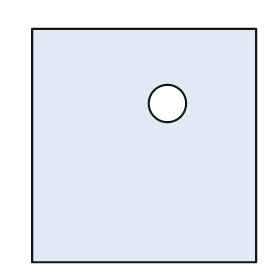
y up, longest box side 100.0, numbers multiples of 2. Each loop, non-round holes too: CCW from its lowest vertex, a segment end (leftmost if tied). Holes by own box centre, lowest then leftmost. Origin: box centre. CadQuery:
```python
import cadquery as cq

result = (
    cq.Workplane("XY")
    .moveTo(-48.0, -50.0)
    .lineTo(48.0, -50.0)
    .lineTo(48.0, 50.0)
    .lineTo(-48.0, 50.0)
    .close()
    .moveTo(10.0, 18.0)
    .circle(8.0)
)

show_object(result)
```